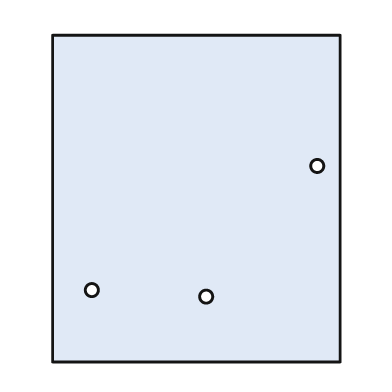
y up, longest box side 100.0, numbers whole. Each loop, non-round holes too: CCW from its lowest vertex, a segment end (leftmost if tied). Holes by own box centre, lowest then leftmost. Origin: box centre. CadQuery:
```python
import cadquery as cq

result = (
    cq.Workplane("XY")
    .moveTo(-44.0, -50.0)
    .lineTo(44.0, -50.0)
    .lineTo(44.0, 50.0)
    .lineTo(-44.0, 50.0)
    .close()
    .moveTo(3.0, -30.0)
    .circle(2.0)
    .moveTo(-32.0, -28.0)
    .circle(2.0)
    .moveTo(37.0, 10.0)
    .circle(2.0)
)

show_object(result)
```